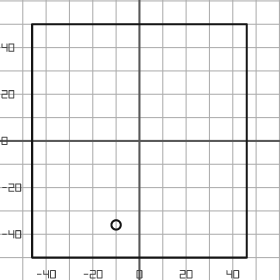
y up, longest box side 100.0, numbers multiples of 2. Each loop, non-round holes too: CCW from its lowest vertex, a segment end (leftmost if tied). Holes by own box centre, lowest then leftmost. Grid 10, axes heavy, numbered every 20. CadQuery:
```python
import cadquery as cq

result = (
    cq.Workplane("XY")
    .moveTo(-46.0, -50.0)
    .lineTo(46.0, -50.0)
    .lineTo(46.0, 50.0)
    .lineTo(-46.0, 50.0)
    .close()
    .moveTo(-10.0, -36.0)
    .circle(2.0)
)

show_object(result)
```